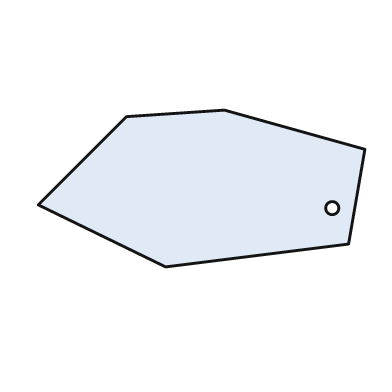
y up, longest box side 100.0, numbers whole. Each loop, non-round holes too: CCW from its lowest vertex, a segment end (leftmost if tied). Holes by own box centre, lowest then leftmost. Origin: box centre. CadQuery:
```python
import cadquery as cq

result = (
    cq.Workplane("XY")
    .moveTo(-11.0, -24.0)
    .lineTo(45.0, -17.0)
    .lineTo(50.0, 12.0)
    .lineTo(7.0, 24.0)
    .lineTo(-23.0, 22.0)
    .lineTo(-50.0, -5.0)
    .close()
    .moveTo(40.0, -6.0)
    .circle(2.0)
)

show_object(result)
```